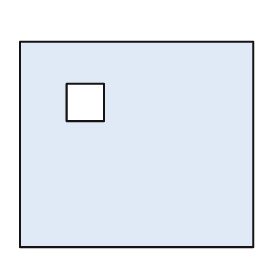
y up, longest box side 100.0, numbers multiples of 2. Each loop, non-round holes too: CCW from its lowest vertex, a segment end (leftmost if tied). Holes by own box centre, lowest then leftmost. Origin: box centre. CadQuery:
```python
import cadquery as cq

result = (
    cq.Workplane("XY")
    .moveTo(-50.0, -44.0)
    .lineTo(50.0, -44.0)
    .lineTo(50.0, 44.0)
    .lineTo(-50.0, 44.0)
    .close()
    .moveTo(-30.0, 10.0)
    .lineTo(-14.0, 10.0)
    .lineTo(-14.0, 26.0)
    .lineTo(-30.0, 26.0)
    .close()
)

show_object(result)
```